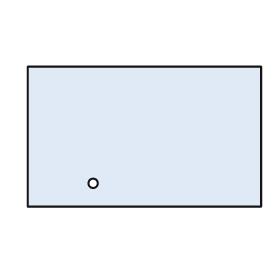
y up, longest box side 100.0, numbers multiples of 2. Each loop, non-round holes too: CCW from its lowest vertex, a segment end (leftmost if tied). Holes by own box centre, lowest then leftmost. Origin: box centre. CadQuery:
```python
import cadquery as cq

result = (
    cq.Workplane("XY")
    .moveTo(-50.0, -30.0)
    .lineTo(50.0, -30.0)
    .lineTo(50.0, 30.0)
    .lineTo(-50.0, 30.0)
    .close()
    .moveTo(-22.0, -20.0)
    .circle(2.0)
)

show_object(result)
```